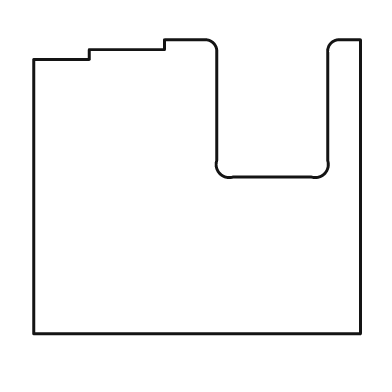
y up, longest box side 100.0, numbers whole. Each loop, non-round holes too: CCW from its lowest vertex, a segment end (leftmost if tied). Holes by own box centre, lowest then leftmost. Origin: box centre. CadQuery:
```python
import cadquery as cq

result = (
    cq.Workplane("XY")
    .moveTo(-50.0, -45.0)
    .lineTo(50.0, -45.0)
    .lineTo(50.0, 45.0)
    .lineTo(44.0, 45.0)
    .threePointArc((41.0, 44.0), (40.0, 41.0))
    .lineTo(40.0, 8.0)
    .threePointArc((39.0, 4.0), (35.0, 3.0))
    .lineTo(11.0, 3.0)
    .threePointArc((7.0, 4.0), (6.0, 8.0))
    .lineTo(6.0, 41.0)
    .threePointArc((5.0, 44.0), (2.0, 45.0))
    .lineTo(-10.0, 45.0)
    .lineTo(-10.0, 42.0)
    .lineTo(-33.0, 42.0)
    .lineTo(-33.0, 39.0)
    .lineTo(-50.0, 39.0)
    .close()
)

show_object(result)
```